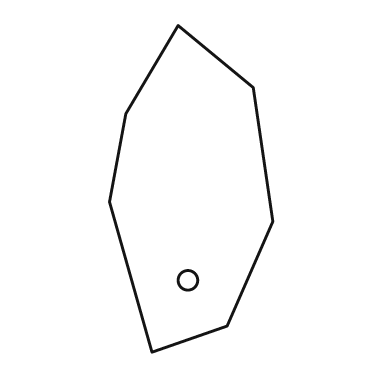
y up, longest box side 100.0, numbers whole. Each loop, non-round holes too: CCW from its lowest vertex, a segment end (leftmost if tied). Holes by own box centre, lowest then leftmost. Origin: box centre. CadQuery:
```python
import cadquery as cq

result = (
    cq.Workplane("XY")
    .moveTo(-12.0, -50.0)
    .lineTo(11.0, -42.0)
    .lineTo(25.0, -10.0)
    .lineTo(19.0, 31.0)
    .lineTo(-4.0, 50.0)
    .lineTo(-20.0, 23.0)
    .lineTo(-25.0, -4.0)
    .close()
    .moveTo(-1.0, -28.0)
    .circle(3.0)
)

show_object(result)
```